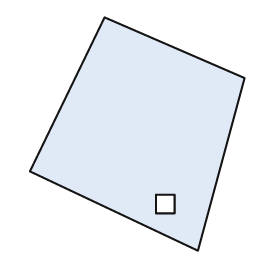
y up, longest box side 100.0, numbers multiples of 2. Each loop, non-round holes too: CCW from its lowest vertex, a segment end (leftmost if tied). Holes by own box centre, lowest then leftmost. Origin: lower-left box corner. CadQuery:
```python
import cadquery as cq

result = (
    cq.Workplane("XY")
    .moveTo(72.0, 0.0)
    .lineTo(92.0, 74.0)
    .lineTo(32.0, 100.0)
    .lineTo(0.0, 34.0)
    .close()
    .moveTo(54.0, 16.0)
    .lineTo(62.0, 16.0)
    .lineTo(62.0, 24.0)
    .lineTo(54.0, 24.0)
    .close()
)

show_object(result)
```